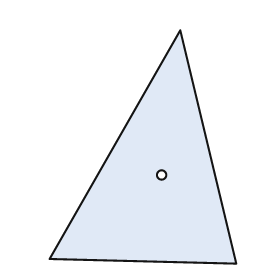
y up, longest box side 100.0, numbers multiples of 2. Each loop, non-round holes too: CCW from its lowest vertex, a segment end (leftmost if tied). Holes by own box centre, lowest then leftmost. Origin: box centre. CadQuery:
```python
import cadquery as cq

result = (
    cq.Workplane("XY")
    .moveTo(40.0, -50.0)
    .lineTo(16.0, 50.0)
    .lineTo(-40.0, -48.0)
    .close()
    .moveTo(8.0, -12.0)
    .circle(2.0)
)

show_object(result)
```